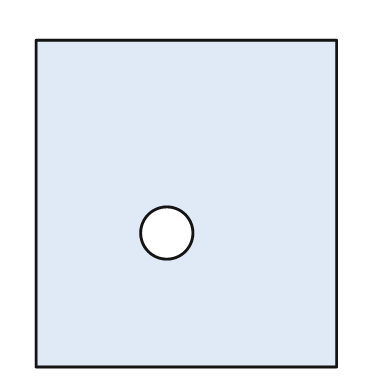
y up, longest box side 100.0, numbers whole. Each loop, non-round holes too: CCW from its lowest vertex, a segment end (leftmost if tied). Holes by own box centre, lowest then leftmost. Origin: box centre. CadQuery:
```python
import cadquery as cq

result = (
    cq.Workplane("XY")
    .moveTo(-46.0, -50.0)
    .lineTo(46.0, -50.0)
    .lineTo(46.0, 50.0)
    .lineTo(-46.0, 50.0)
    .close()
    .moveTo(-6.0, -9.0)
    .circle(8.0)
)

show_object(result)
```